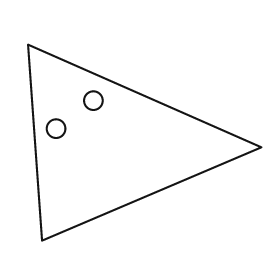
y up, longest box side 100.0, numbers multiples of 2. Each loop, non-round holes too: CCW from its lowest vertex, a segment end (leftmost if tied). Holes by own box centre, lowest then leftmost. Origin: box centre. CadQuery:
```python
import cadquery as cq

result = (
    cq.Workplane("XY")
    .moveTo(-44.0, -42.0)
    .lineTo(50.0, -2.0)
    .lineTo(-50.0, 42.0)
    .close()
    .moveTo(-38.0, 6.0)
    .circle(4.0)
    .moveTo(-22.0, 18.0)
    .circle(4.0)
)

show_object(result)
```